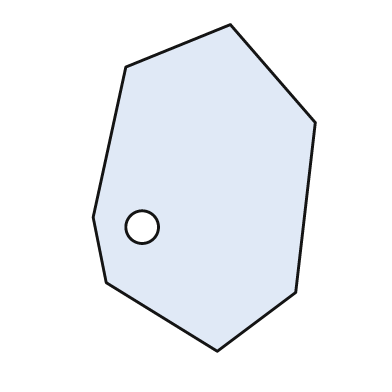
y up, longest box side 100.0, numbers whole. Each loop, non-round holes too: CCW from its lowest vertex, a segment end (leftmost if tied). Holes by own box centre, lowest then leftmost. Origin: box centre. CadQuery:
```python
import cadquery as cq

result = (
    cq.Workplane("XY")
    .moveTo(4.0, -50.0)
    .lineTo(28.0, -32.0)
    .lineTo(34.0, 20.0)
    .lineTo(8.0, 50.0)
    .lineTo(-24.0, 37.0)
    .lineTo(-34.0, -9.0)
    .lineTo(-30.0, -29.0)
    .close()
    .moveTo(-19.0, -12.0)
    .circle(5.0)
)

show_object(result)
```